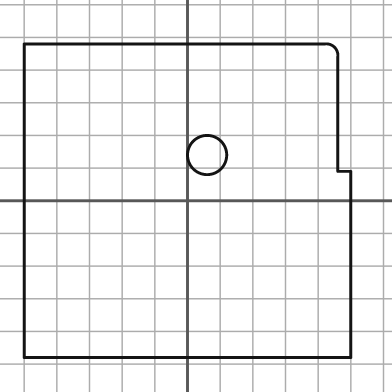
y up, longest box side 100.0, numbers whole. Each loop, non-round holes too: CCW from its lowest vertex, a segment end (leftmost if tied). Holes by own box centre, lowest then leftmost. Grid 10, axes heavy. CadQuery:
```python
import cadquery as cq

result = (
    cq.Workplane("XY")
    .moveTo(-50.0, -48.0)
    .lineTo(50.0, -48.0)
    .lineTo(50.0, 9.0)
    .lineTo(46.0, 9.0)
    .lineTo(46.0, 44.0)
    .threePointArc((45.0, 47.0), (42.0, 48.0))
    .lineTo(-50.0, 48.0)
    .close()
    .moveTo(6.0, 14.0)
    .circle(6.0)
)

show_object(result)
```